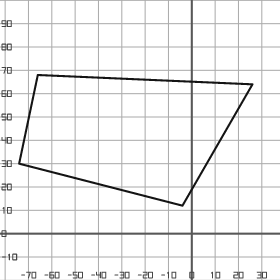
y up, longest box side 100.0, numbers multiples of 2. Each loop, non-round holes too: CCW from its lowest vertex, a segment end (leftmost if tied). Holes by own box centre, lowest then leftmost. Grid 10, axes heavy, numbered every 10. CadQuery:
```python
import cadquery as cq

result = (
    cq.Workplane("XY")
    .moveTo(-4.0, 12.0)
    .lineTo(26.0, 64.0)
    .lineTo(-66.0, 68.0)
    .lineTo(-74.0, 30.0)
    .close()
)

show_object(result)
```